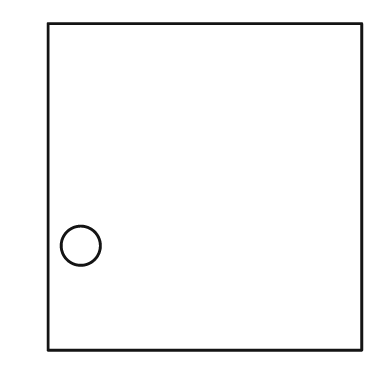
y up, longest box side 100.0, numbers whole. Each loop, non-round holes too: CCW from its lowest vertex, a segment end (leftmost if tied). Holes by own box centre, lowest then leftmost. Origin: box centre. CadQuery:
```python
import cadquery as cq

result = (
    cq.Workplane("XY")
    .moveTo(-48.0, -50.0)
    .lineTo(48.0, -50.0)
    .lineTo(48.0, 50.0)
    .lineTo(-48.0, 50.0)
    .close()
    .moveTo(-38.0, -18.0)
    .circle(6.0)
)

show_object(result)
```